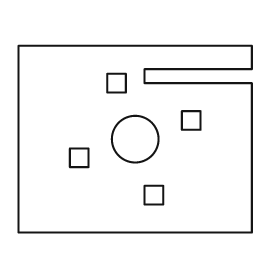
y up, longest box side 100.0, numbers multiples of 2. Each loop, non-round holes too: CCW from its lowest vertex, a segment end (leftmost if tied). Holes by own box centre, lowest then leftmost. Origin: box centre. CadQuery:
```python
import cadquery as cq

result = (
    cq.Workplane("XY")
    .moveTo(-50.0, -40.0)
    .lineTo(50.0, -40.0)
    .lineTo(50.0, 24.0)
    .lineTo(4.0, 24.0)
    .lineTo(4.0, 30.0)
    .lineTo(50.0, 30.0)
    .lineTo(50.0, 40.0)
    .lineTo(-50.0, 40.0)
    .close()
    .moveTo(4.0, -28.0)
    .lineTo(12.0, -28.0)
    .lineTo(12.0, -20.0)
    .lineTo(4.0, -20.0)
    .close()
    .moveTo(-28.0, -12.0)
    .lineTo(-20.0, -12.0)
    .lineTo(-20.0, -4.0)
    .lineTo(-28.0, -4.0)
    .close()
    .moveTo(0.0, 0.0)
    .circle(10.0)
    .moveTo(20.0, 4.0)
    .lineTo(28.0, 4.0)
    .lineTo(28.0, 12.0)
    .lineTo(20.0, 12.0)
    .close()
    .moveTo(-12.0, 20.0)
    .lineTo(-4.0, 20.0)
    .lineTo(-4.0, 28.0)
    .lineTo(-12.0, 28.0)
    .close()
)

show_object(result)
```